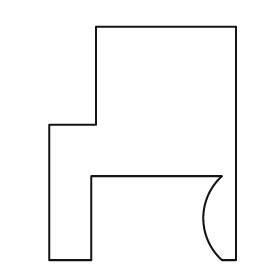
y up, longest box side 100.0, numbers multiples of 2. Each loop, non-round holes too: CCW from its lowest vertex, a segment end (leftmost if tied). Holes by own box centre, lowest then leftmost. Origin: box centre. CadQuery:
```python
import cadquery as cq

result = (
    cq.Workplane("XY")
    .moveTo(-40.0, -50.0)
    .lineTo(-22.0, -50.0)
    .lineTo(-22.0, -14.0)
    .lineTo(34.0, -14.0)
    .threePointArc((26.0, -32.0), (34.0, -50.0))
    .lineTo(40.0, -50.0)
    .lineTo(40.0, 50.0)
    .lineTo(-20.0, 50.0)
    .lineTo(-20.0, 8.0)
    .lineTo(-40.0, 8.0)
    .close()
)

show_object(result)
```